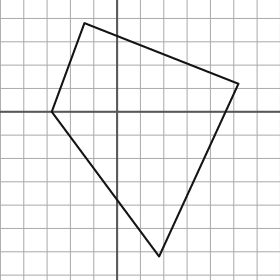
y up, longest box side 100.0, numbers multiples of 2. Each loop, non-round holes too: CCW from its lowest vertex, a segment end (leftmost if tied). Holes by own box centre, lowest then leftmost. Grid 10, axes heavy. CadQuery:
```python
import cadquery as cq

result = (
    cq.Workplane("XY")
    .moveTo(18.0, -62.0)
    .lineTo(52.0, 12.0)
    .lineTo(-14.0, 38.0)
    .lineTo(-28.0, 0.0)
    .close()
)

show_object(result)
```